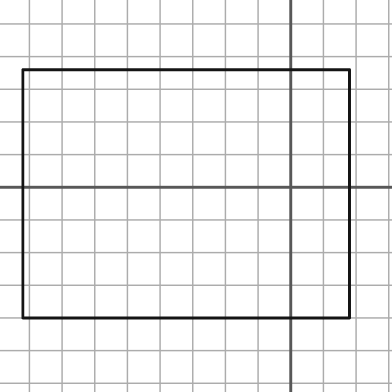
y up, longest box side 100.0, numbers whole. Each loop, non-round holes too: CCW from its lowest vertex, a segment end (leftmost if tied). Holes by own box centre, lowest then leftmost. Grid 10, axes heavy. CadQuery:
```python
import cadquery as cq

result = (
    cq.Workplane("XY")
    .moveTo(-82.0, -40.0)
    .lineTo(18.0, -40.0)
    .lineTo(18.0, 36.0)
    .lineTo(-82.0, 36.0)
    .close()
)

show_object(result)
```